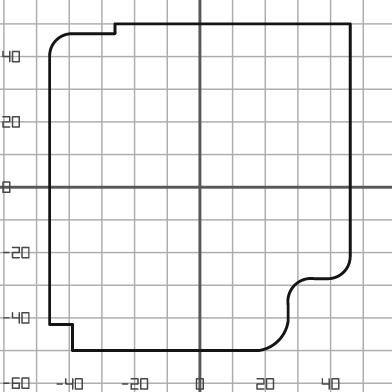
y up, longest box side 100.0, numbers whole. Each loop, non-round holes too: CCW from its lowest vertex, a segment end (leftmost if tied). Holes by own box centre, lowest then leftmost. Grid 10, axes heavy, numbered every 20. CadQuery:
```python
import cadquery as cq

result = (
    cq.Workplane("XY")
    .moveTo(-39.0, -50.0)
    .lineTo(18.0, -50.0)
    .threePointArc((24.0, -47.0), (27.0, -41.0))
    .lineTo(27.0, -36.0)
    .threePointArc((29.0, -30.0), (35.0, -28.0))
    .lineTo(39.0, -28.0)
    .threePointArc((44.0, -26.0), (46.0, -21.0))
    .lineTo(46.0, 50.0)
    .lineTo(-26.0, 50.0)
    .lineTo(-26.0, 47.0)
    .lineTo(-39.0, 47.0)
    .threePointArc((-44.0, 45.0), (-46.0, 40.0))
    .lineTo(-46.0, -42.0)
    .lineTo(-39.0, -42.0)
    .close()
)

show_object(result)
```